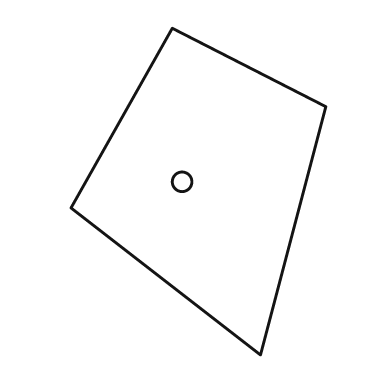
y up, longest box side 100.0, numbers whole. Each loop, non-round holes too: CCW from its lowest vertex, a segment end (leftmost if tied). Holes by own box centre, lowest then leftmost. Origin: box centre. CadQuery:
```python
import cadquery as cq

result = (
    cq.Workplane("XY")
    .moveTo(19.0, -50.0)
    .lineTo(39.0, 26.0)
    .lineTo(-8.0, 50.0)
    .lineTo(-39.0, -5.0)
    .close()
    .moveTo(-5.0, 3.0)
    .circle(3.0)
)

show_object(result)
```